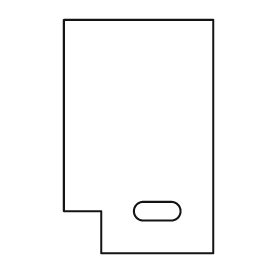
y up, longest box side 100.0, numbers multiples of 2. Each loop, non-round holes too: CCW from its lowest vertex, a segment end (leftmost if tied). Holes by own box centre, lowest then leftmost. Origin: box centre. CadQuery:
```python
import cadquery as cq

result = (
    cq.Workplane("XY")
    .moveTo(-16.0, -50.0)
    .lineTo(32.0, -50.0)
    .lineTo(32.0, 50.0)
    .lineTo(-32.0, 50.0)
    .lineTo(-32.0, -32.0)
    .lineTo(-16.0, -32.0)
    .close()
    .moveTo(2.0, -36.0)
    .lineTo(14.0, -36.0)
    .threePointArc((18.0, -32.0), (14.0, -28.0))
    .lineTo(2.0, -28.0)
    .threePointArc((-2.0, -32.0), (2.0, -36.0))
    .close()
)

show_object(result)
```